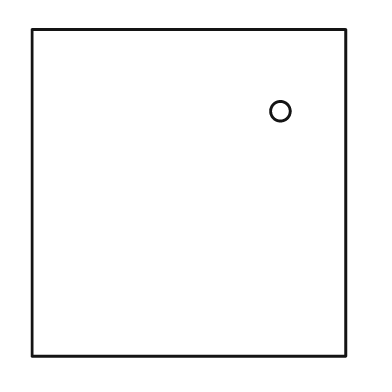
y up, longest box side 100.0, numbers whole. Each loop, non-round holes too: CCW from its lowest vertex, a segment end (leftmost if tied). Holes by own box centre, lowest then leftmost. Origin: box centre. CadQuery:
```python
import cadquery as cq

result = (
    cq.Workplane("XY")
    .moveTo(-48.0, -50.0)
    .lineTo(48.0, -50.0)
    .lineTo(48.0, 50.0)
    .lineTo(-48.0, 50.0)
    .close()
    .moveTo(28.0, 25.0)
    .circle(3.0)
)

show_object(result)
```